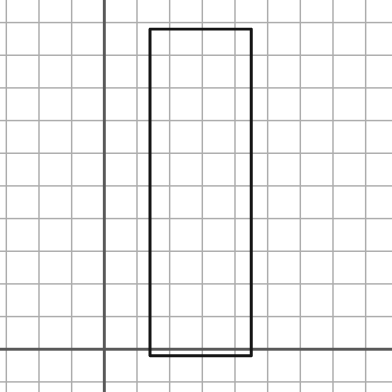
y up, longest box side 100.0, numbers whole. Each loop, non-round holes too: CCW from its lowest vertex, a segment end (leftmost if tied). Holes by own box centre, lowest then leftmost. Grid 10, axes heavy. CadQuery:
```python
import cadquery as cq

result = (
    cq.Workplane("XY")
    .moveTo(14.0, -2.0)
    .lineTo(45.0, -2.0)
    .lineTo(45.0, 98.0)
    .lineTo(14.0, 98.0)
    .close()
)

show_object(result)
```